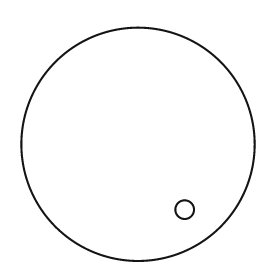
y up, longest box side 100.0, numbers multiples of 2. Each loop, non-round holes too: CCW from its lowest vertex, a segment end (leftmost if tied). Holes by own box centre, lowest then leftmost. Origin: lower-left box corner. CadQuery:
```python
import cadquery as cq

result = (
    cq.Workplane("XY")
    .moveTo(50.0, 50.0)
    .circle(50.0)
    .moveTo(70.0, 22.0)
    .circle(4.0)
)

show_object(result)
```